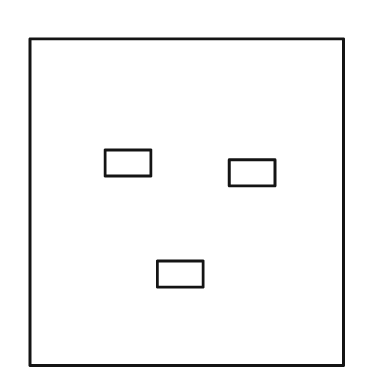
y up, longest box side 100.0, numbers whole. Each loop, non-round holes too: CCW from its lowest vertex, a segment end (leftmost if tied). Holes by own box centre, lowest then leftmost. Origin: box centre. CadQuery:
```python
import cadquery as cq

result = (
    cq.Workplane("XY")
    .moveTo(-48.0, -50.0)
    .lineTo(48.0, -50.0)
    .lineTo(48.0, 50.0)
    .lineTo(-48.0, 50.0)
    .close()
    .moveTo(-9.0, -26.0)
    .lineTo(5.0, -26.0)
    .lineTo(5.0, -18.0)
    .lineTo(-9.0, -18.0)
    .close()
    .moveTo(13.0, 5.0)
    .lineTo(27.0, 5.0)
    .lineTo(27.0, 13.0)
    .lineTo(13.0, 13.0)
    .close()
    .moveTo(-25.0, 8.0)
    .lineTo(-11.0, 8.0)
    .lineTo(-11.0, 16.0)
    .lineTo(-25.0, 16.0)
    .close()
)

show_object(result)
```